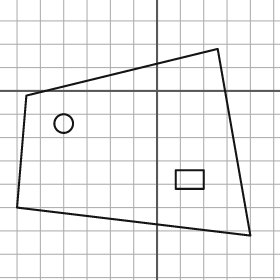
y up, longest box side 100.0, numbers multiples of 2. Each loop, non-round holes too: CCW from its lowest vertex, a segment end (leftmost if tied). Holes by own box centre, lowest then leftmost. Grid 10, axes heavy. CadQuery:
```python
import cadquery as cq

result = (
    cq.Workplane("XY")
    .moveTo(40.0, -62.0)
    .lineTo(26.0, 18.0)
    .lineTo(-56.0, -2.0)
    .lineTo(-60.0, -50.0)
    .close()
    .moveTo(8.0, -42.0)
    .lineTo(20.0, -42.0)
    .lineTo(20.0, -34.0)
    .lineTo(8.0, -34.0)
    .close()
    .moveTo(-40.0, -14.0)
    .circle(4.0)
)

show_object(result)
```